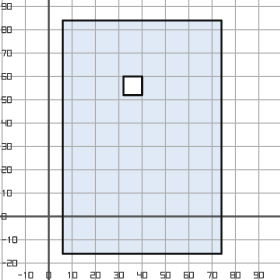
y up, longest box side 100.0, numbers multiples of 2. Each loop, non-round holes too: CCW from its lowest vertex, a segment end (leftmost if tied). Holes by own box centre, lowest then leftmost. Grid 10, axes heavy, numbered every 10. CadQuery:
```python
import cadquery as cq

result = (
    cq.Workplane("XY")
    .moveTo(6.0, -16.0)
    .lineTo(74.0, -16.0)
    .lineTo(74.0, 84.0)
    .lineTo(6.0, 84.0)
    .close()
    .moveTo(32.0, 52.0)
    .lineTo(40.0, 52.0)
    .lineTo(40.0, 60.0)
    .lineTo(32.0, 60.0)
    .close()
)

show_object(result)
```